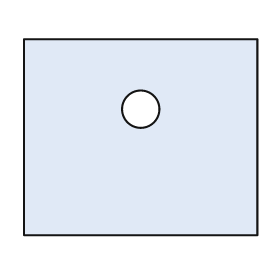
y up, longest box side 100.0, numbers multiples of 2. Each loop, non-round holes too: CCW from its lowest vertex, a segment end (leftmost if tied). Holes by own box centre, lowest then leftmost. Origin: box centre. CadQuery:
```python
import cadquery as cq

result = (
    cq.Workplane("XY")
    .moveTo(-50.0, -42.0)
    .lineTo(50.0, -42.0)
    .lineTo(50.0, 42.0)
    .lineTo(-50.0, 42.0)
    .close()
    .moveTo(0.0, 12.0)
    .circle(8.0)
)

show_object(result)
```